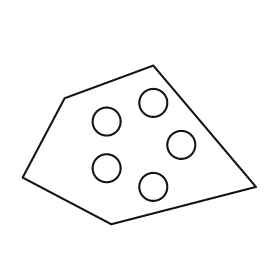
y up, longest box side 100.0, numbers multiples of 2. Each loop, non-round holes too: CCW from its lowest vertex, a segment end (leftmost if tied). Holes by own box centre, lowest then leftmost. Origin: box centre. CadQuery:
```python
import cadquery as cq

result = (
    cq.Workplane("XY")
    .moveTo(-12.0, -34.0)
    .lineTo(50.0, -18.0)
    .lineTo(6.0, 34.0)
    .lineTo(-32.0, 20.0)
    .lineTo(-50.0, -14.0)
    .close()
    .moveTo(6.0, -18.0)
    .circle(6.0)
    .moveTo(-14.0, -10.0)
    .circle(6.0)
    .moveTo(18.0, 0.0)
    .circle(6.0)
    .moveTo(-14.0, 10.0)
    .circle(6.0)
    .moveTo(6.0, 18.0)
    .circle(6.0)
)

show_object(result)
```